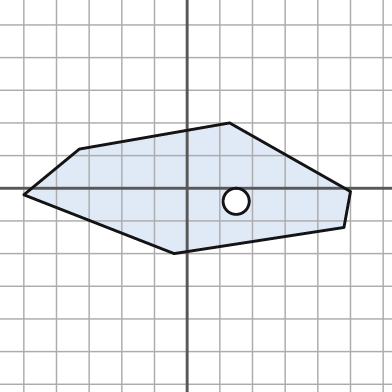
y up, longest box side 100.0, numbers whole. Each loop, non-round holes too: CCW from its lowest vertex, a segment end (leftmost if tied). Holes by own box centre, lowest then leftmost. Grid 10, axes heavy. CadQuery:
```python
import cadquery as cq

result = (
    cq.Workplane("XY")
    .moveTo(-4.0, -20.0)
    .lineTo(48.0, -12.0)
    .lineTo(50.0, -1.0)
    .lineTo(13.0, 20.0)
    .lineTo(-33.0, 12.0)
    .lineTo(-50.0, -2.0)
    .close()
    .moveTo(15.0, -4.0)
    .circle(4.0)
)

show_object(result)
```